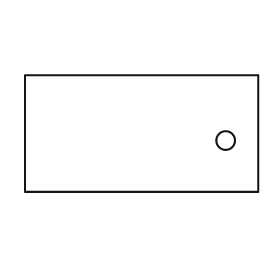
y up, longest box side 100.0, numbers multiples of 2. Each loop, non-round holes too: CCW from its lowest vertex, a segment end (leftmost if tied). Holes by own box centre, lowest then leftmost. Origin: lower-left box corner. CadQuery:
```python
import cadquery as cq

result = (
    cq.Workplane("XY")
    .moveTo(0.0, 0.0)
    .lineTo(100.0, 0.0)
    .lineTo(100.0, 50.0)
    .lineTo(0.0, 50.0)
    .close()
    .moveTo(86.0, 22.0)
    .circle(4.0)
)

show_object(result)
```